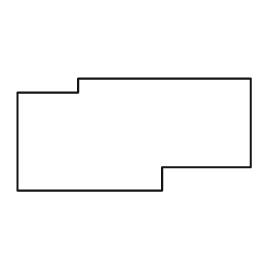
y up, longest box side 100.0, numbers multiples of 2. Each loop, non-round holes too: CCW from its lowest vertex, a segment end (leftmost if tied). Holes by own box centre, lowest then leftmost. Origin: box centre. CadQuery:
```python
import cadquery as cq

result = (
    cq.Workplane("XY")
    .moveTo(-50.0, -24.0)
    .lineTo(12.0, -24.0)
    .lineTo(12.0, -14.0)
    .lineTo(50.0, -14.0)
    .lineTo(50.0, 24.0)
    .lineTo(-24.0, 24.0)
    .lineTo(-24.0, 18.0)
    .lineTo(-50.0, 18.0)
    .close()
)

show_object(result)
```